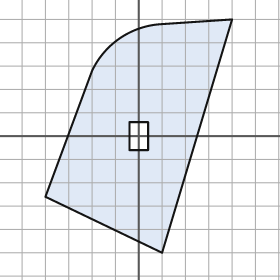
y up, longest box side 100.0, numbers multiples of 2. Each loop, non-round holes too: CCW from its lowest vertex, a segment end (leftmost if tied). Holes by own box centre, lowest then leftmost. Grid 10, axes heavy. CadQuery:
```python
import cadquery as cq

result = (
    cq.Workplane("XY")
    .moveTo(10.0, -50.0)
    .lineTo(40.0, 50.0)
    .lineTo(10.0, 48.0)
    .threePointArc((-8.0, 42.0), (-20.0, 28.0))
    .lineTo(-40.0, -26.0)
    .close()
    .moveTo(-4.0, -6.0)
    .lineTo(4.0, -6.0)
    .lineTo(4.0, 6.0)
    .lineTo(-4.0, 6.0)
    .close()
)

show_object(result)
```